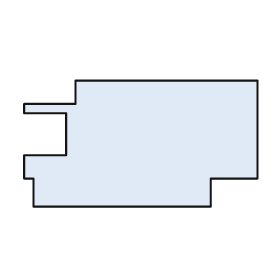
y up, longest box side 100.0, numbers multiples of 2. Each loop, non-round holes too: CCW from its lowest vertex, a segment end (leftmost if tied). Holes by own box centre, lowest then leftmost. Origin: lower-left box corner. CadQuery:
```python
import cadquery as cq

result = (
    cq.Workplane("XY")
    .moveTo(4.0, 0.0)
    .lineTo(80.0, 0.0)
    .lineTo(80.0, 12.0)
    .lineTo(100.0, 12.0)
    .lineTo(100.0, 54.0)
    .lineTo(22.0, 54.0)
    .lineTo(22.0, 44.0)
    .lineTo(0.0, 44.0)
    .lineTo(0.0, 40.0)
    .lineTo(18.0, 40.0)
    .lineTo(18.0, 22.0)
    .lineTo(0.0, 22.0)
    .lineTo(0.0, 12.0)
    .lineTo(4.0, 12.0)
    .close()
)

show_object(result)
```